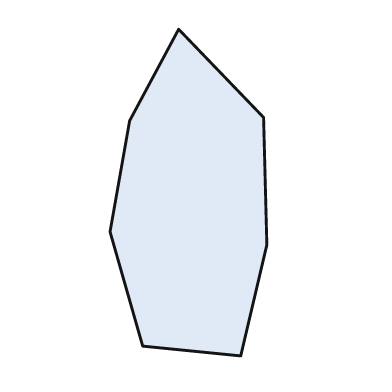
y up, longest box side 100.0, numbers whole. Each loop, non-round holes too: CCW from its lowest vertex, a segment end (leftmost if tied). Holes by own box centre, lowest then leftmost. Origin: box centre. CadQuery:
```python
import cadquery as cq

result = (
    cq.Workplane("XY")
    .moveTo(16.0, -50.0)
    .lineTo(24.0, -16.0)
    .lineTo(23.0, 23.0)
    .lineTo(-3.0, 50.0)
    .lineTo(-18.0, 22.0)
    .lineTo(-24.0, -12.0)
    .lineTo(-14.0, -47.0)
    .close()
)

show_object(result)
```